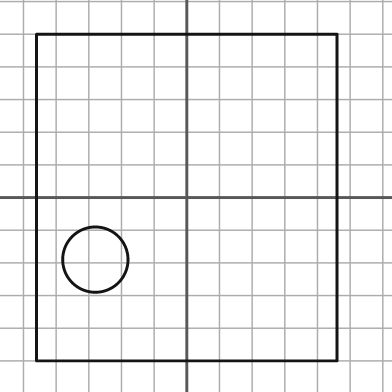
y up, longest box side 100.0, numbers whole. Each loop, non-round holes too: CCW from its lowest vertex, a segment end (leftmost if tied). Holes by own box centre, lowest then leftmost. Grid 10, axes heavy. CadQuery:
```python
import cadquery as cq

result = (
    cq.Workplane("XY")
    .moveTo(-46.0, -50.0)
    .lineTo(46.0, -50.0)
    .lineTo(46.0, 50.0)
    .lineTo(-46.0, 50.0)
    .close()
    .moveTo(-28.0, -19.0)
    .circle(10.0)
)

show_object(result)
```